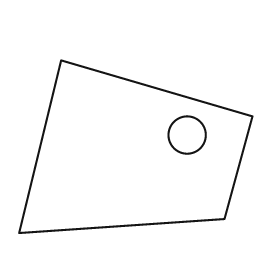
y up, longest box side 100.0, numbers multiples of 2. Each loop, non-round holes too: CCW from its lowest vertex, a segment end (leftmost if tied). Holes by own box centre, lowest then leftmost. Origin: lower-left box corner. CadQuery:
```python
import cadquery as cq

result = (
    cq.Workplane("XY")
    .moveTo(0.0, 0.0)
    .lineTo(88.0, 6.0)
    .lineTo(100.0, 50.0)
    .lineTo(18.0, 74.0)
    .close()
    .moveTo(72.0, 42.0)
    .circle(8.0)
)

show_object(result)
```